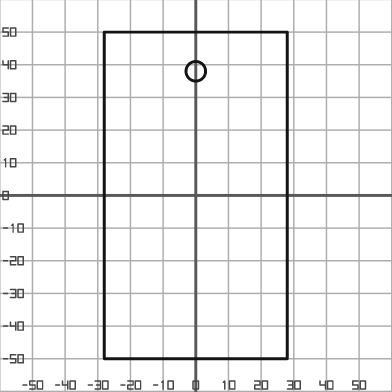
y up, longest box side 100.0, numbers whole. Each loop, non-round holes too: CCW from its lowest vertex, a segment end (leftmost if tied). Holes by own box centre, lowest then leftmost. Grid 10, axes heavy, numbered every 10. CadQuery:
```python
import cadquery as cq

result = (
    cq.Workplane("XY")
    .moveTo(-28.0, -50.0)
    .lineTo(28.0, -50.0)
    .lineTo(28.0, 50.0)
    .lineTo(-28.0, 50.0)
    .close()
    .moveTo(0.0, 38.0)
    .circle(3.0)
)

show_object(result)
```